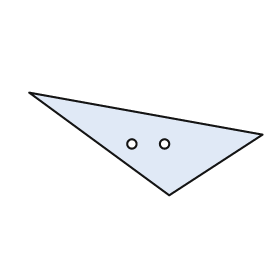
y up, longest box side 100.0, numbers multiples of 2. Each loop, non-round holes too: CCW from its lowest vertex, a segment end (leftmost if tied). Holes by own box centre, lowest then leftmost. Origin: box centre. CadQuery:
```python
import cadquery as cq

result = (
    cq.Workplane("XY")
    .moveTo(10.0, -22.0)
    .lineTo(50.0, 4.0)
    .lineTo(-50.0, 22.0)
    .close()
    .moveTo(-6.0, 0.0)
    .circle(2.0)
    .moveTo(8.0, 0.0)
    .circle(2.0)
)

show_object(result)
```